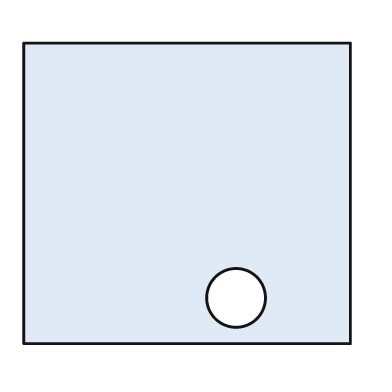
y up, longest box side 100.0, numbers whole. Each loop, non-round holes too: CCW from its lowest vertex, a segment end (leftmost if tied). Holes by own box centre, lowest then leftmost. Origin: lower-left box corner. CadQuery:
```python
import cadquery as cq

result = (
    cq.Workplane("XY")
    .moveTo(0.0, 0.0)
    .lineTo(100.0, 0.0)
    .lineTo(100.0, 92.0)
    .lineTo(0.0, 92.0)
    .close()
    .moveTo(65.0, 14.0)
    .circle(9.0)
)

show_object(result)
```